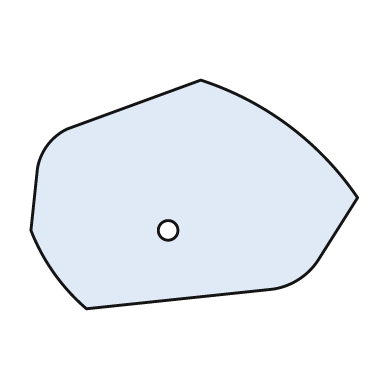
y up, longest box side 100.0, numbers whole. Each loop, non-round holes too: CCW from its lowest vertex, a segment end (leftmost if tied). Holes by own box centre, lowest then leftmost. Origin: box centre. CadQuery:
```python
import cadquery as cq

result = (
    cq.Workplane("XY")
    .moveTo(-33.0, -35.0)
    .lineTo(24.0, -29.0)
    .threePointArc((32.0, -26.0), (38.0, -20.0))
    .lineTo(50.0, -1.0)
    .threePointArc((29.0, 21.0), (2.0, 35.0))
    .lineTo(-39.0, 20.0)
    .threePointArc((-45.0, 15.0), (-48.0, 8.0))
    .lineTo(-50.0, -11.0)
    .threePointArc((-43.0, -24.0), (-33.0, -35.0))
    .close()
    .moveTo(-8.0, -11.0)
    .circle(3.0)
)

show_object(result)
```